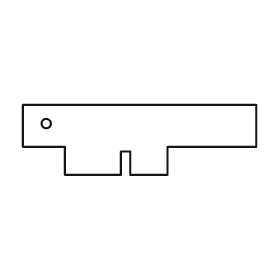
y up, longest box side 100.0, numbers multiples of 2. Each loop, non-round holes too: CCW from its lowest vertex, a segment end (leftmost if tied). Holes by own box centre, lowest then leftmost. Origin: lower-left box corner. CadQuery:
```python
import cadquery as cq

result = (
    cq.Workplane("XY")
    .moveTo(18.0, 0.0)
    .lineTo(42.0, 0.0)
    .lineTo(42.0, 10.0)
    .lineTo(46.0, 10.0)
    .lineTo(46.0, 0.0)
    .lineTo(62.0, 0.0)
    .lineTo(62.0, 12.0)
    .lineTo(100.0, 12.0)
    .lineTo(100.0, 30.0)
    .lineTo(0.0, 30.0)
    .lineTo(0.0, 12.0)
    .lineTo(18.0, 12.0)
    .close()
    .moveTo(10.0, 22.0)
    .circle(2.0)
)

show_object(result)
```